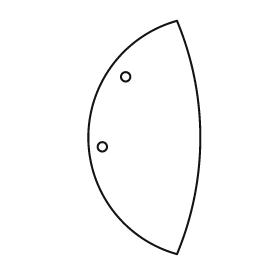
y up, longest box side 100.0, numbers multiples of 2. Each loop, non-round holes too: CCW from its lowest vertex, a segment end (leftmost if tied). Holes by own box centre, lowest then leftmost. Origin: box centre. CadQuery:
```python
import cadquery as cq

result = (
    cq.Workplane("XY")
    .moveTo(14.0, -50.0)
    .threePointArc((24.0, 0.0), (14.0, 50.0))
    .threePointArc((-24.0, 0.0), (14.0, -50.0))
    .close()
    .moveTo(-18.0, -4.0)
    .circle(2.0)
    .moveTo(-8.0, 26.0)
    .circle(2.0)
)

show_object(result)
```